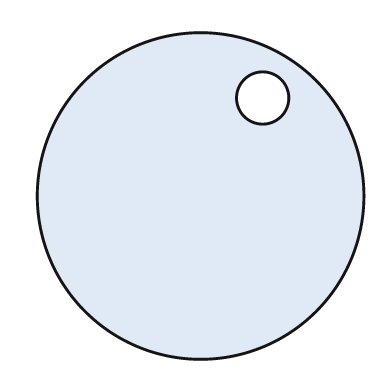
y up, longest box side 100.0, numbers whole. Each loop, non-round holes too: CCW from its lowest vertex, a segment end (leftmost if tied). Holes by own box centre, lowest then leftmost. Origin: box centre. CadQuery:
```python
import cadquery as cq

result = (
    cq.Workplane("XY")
    .moveTo(0.0, 0.0)
    .circle(50.0)
    .moveTo(19.0, 30.0)
    .circle(8.0)
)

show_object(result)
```